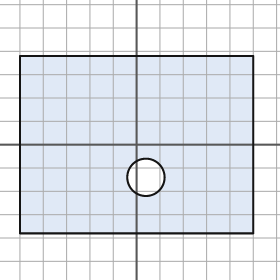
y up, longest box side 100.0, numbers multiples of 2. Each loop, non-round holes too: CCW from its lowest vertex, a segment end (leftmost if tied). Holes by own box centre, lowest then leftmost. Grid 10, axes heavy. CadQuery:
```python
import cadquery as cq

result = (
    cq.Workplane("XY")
    .moveTo(-50.0, -38.0)
    .lineTo(50.0, -38.0)
    .lineTo(50.0, 38.0)
    .lineTo(-50.0, 38.0)
    .close()
    .moveTo(4.0, -14.0)
    .circle(8.0)
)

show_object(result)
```